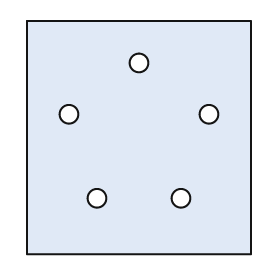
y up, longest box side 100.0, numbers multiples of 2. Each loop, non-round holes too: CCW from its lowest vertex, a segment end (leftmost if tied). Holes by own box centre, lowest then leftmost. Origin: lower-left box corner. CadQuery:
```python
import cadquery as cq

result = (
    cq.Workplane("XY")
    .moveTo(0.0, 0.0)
    .lineTo(96.0, 0.0)
    .lineTo(96.0, 100.0)
    .lineTo(0.0, 100.0)
    .close()
    .moveTo(30.0, 24.0)
    .circle(4.0)
    .moveTo(66.0, 24.0)
    .circle(4.0)
    .moveTo(18.0, 60.0)
    .circle(4.0)
    .moveTo(78.0, 60.0)
    .circle(4.0)
    .moveTo(48.0, 82.0)
    .circle(4.0)
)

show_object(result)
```